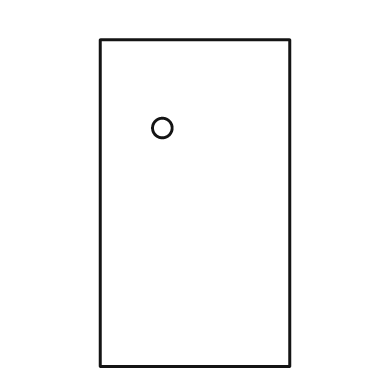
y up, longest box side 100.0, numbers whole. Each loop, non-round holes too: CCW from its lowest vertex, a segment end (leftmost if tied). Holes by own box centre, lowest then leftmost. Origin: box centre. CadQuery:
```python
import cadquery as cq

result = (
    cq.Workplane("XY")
    .moveTo(-29.0, -50.0)
    .lineTo(29.0, -50.0)
    .lineTo(29.0, 50.0)
    .lineTo(-29.0, 50.0)
    .close()
    .moveTo(-10.0, 23.0)
    .circle(3.0)
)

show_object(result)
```